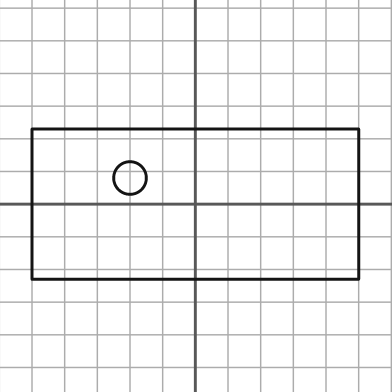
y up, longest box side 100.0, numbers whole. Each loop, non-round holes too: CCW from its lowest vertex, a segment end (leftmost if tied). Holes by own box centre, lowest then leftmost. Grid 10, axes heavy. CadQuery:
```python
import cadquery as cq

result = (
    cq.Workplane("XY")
    .moveTo(-50.0, -23.0)
    .lineTo(50.0, -23.0)
    .lineTo(50.0, 23.0)
    .lineTo(-50.0, 23.0)
    .close()
    .moveTo(-20.0, 8.0)
    .circle(5.0)
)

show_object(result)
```